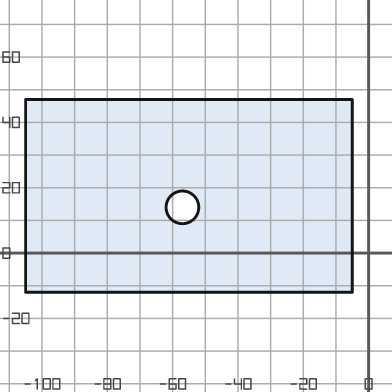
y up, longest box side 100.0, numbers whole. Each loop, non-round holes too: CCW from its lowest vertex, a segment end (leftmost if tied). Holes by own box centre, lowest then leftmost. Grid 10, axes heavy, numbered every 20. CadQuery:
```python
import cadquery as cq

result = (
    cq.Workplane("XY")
    .moveTo(-105.0, -12.0)
    .lineTo(-5.0, -12.0)
    .lineTo(-5.0, 47.0)
    .lineTo(-105.0, 47.0)
    .close()
    .moveTo(-57.0, 14.0)
    .circle(5.0)
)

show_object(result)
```